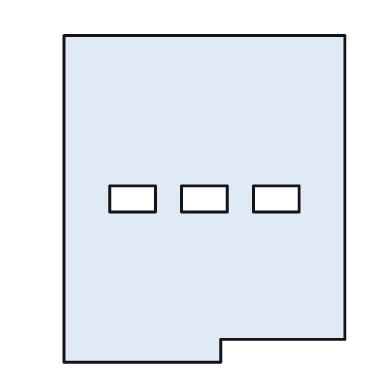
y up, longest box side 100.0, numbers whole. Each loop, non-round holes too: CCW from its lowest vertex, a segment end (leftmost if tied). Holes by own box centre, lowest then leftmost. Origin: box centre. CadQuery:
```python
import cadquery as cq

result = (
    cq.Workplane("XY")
    .moveTo(-43.0, -50.0)
    .lineTo(5.0, -50.0)
    .lineTo(5.0, -43.0)
    .lineTo(43.0, -43.0)
    .lineTo(43.0, 50.0)
    .lineTo(-43.0, 50.0)
    .close()
    .moveTo(-29.0, -4.0)
    .lineTo(-15.0, -4.0)
    .lineTo(-15.0, 4.0)
    .lineTo(-29.0, 4.0)
    .close()
    .moveTo(-7.0, -4.0)
    .lineTo(7.0, -4.0)
    .lineTo(7.0, 4.0)
    .lineTo(-7.0, 4.0)
    .close()
    .moveTo(15.0, -4.0)
    .lineTo(29.0, -4.0)
    .lineTo(29.0, 4.0)
    .lineTo(15.0, 4.0)
    .close()
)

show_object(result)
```